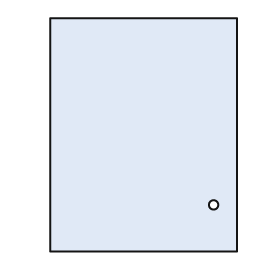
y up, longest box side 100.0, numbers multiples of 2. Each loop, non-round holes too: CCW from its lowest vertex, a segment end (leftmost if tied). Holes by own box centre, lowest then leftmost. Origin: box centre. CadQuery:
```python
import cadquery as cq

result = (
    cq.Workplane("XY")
    .moveTo(-40.0, -50.0)
    .lineTo(40.0, -50.0)
    .lineTo(40.0, 50.0)
    .lineTo(-40.0, 50.0)
    .close()
    .moveTo(30.0, -30.0)
    .circle(2.0)
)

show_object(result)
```